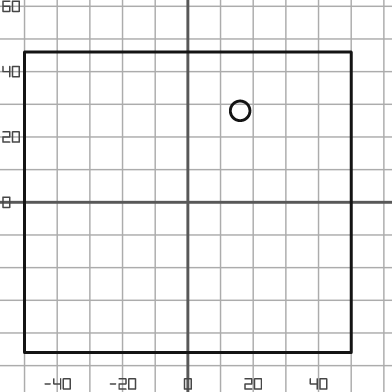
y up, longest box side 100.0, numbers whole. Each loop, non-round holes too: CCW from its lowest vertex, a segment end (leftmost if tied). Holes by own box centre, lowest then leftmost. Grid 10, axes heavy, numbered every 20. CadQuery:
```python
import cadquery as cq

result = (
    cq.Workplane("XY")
    .moveTo(-50.0, -46.0)
    .lineTo(50.0, -46.0)
    .lineTo(50.0, 46.0)
    .lineTo(-50.0, 46.0)
    .close()
    .moveTo(16.0, 28.0)
    .circle(3.0)
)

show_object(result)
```